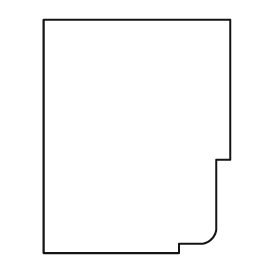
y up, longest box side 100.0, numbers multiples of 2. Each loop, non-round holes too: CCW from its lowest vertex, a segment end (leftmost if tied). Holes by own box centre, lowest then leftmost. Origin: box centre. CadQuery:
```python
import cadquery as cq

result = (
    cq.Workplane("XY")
    .moveTo(-40.0, -50.0)
    .lineTo(18.0, -50.0)
    .lineTo(18.0, -46.0)
    .lineTo(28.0, -46.0)
    .threePointArc((32.0, -44.0), (34.0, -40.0))
    .lineTo(34.0, -10.0)
    .lineTo(40.0, -10.0)
    .lineTo(40.0, 50.0)
    .lineTo(-40.0, 50.0)
    .close()
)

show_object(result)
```